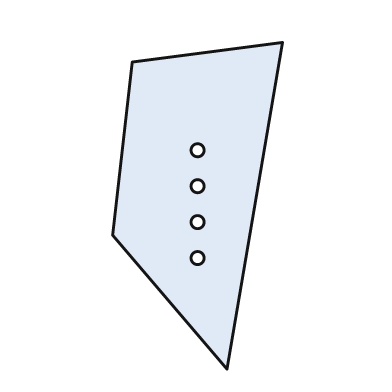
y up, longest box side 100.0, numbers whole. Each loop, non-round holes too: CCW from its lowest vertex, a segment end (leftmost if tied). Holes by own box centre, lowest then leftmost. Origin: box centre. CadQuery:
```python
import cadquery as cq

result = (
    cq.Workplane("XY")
    .moveTo(9.0, -50.0)
    .lineTo(26.0, 50.0)
    .lineTo(-20.0, 44.0)
    .lineTo(-26.0, -9.0)
    .close()
    .moveTo(0.0, -16.0)
    .circle(2.0)
    .moveTo(0.0, -5.0)
    .circle(2.0)
    .moveTo(0.0, 6.0)
    .circle(2.0)
    .moveTo(0.0, 17.0)
    .circle(2.0)
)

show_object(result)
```